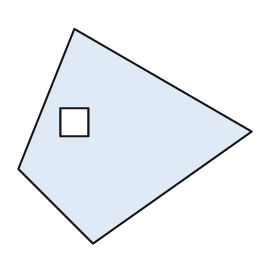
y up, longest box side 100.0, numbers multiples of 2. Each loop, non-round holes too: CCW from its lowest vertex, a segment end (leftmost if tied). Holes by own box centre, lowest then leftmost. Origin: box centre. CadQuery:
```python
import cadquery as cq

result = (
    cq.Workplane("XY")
    .moveTo(-18.0, -46.0)
    .lineTo(50.0, 2.0)
    .lineTo(-26.0, 46.0)
    .lineTo(-50.0, -14.0)
    .close()
    .moveTo(-32.0, 0.0)
    .lineTo(-20.0, 0.0)
    .lineTo(-20.0, 12.0)
    .lineTo(-32.0, 12.0)
    .close()
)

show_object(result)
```